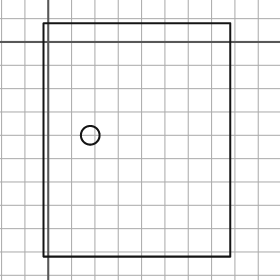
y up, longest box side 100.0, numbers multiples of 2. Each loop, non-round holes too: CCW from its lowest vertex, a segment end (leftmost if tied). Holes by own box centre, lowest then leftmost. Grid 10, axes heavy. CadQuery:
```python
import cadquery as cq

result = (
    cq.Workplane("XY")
    .moveTo(-2.0, -92.0)
    .lineTo(78.0, -92.0)
    .lineTo(78.0, 8.0)
    .lineTo(-2.0, 8.0)
    .close()
    .moveTo(18.0, -40.0)
    .circle(4.0)
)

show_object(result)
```